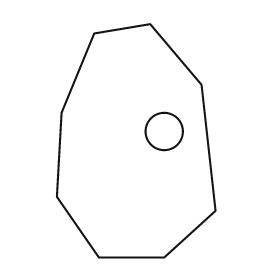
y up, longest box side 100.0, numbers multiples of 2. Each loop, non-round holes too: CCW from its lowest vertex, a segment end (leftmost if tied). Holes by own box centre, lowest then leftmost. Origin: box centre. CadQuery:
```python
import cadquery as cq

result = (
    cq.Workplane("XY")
    .moveTo(-16.0, -50.0)
    .lineTo(12.0, -50.0)
    .lineTo(34.0, -30.0)
    .lineTo(28.0, 24.0)
    .lineTo(6.0, 50.0)
    .lineTo(-18.0, 46.0)
    .lineTo(-32.0, 12.0)
    .lineTo(-34.0, -24.0)
    .close()
    .moveTo(12.0, 4.0)
    .circle(8.0)
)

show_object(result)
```